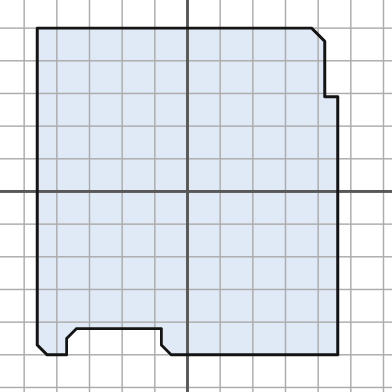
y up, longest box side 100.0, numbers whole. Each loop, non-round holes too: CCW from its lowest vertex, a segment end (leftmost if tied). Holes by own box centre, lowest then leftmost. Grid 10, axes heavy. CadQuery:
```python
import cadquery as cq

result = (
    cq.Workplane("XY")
    .moveTo(-43.0, -50.0)
    .lineTo(-37.0, -50.0)
    .lineTo(-37.0, -45.0)
    .lineTo(-34.0, -42.0)
    .lineTo(-8.0, -42.0)
    .lineTo(-8.0, -47.0)
    .lineTo(-5.0, -50.0)
    .lineTo(46.0, -50.0)
    .lineTo(46.0, 29.0)
    .lineTo(42.0, 29.0)
    .lineTo(42.0, 46.0)
    .lineTo(38.0, 50.0)
    .lineTo(-46.0, 50.0)
    .lineTo(-46.0, -47.0)
    .close()
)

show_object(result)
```